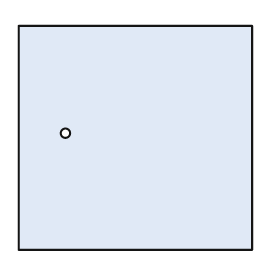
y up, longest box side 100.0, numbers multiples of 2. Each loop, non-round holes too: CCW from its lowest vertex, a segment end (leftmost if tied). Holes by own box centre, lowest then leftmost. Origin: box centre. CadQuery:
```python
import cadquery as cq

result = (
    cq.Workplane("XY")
    .moveTo(-50.0, -48.0)
    .lineTo(50.0, -48.0)
    .lineTo(50.0, 48.0)
    .lineTo(-50.0, 48.0)
    .close()
    .moveTo(-30.0, 2.0)
    .circle(2.0)
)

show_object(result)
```